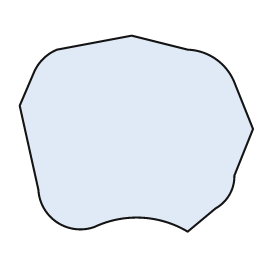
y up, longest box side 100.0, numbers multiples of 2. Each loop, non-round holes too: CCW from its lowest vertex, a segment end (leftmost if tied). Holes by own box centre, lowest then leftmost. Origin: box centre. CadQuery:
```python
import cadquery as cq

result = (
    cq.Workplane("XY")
    .moveTo(22.0, -42.0)
    .lineTo(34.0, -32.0)
    .threePointArc((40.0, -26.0), (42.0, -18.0))
    .lineTo(50.0, 2.0)
    .lineTo(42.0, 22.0)
    .threePointArc((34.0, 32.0), (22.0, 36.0))
    .lineTo(-2.0, 42.0)
    .lineTo(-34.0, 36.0)
    .threePointArc((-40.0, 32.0), (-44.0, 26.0))
    .lineTo(-50.0, 12.0)
    .lineTo(-42.0, -24.0)
    .threePointArc((-34.0, -38.0), (-18.0, -40.0))
    .threePointArc((2.0, -36.0), (22.0, -42.0))
    .close()
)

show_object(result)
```